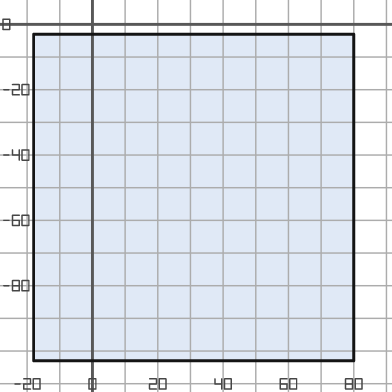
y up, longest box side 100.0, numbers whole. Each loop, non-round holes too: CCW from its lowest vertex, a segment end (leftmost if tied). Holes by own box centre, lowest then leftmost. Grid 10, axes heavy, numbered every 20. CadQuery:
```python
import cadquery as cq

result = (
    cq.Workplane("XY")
    .moveTo(-18.0, -103.0)
    .lineTo(80.0, -103.0)
    .lineTo(80.0, -3.0)
    .lineTo(-18.0, -3.0)
    .close()
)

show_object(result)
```